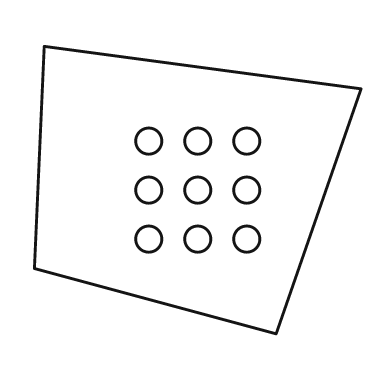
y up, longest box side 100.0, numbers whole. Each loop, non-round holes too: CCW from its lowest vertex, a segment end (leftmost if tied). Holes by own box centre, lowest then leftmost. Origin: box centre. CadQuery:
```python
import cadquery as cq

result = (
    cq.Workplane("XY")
    .moveTo(24.0, -44.0)
    .lineTo(50.0, 31.0)
    .lineTo(-47.0, 44.0)
    .lineTo(-50.0, -24.0)
    .close()
    .moveTo(-15.0, -15.0)
    .circle(4.0)
    .moveTo(0.0, -15.0)
    .circle(4.0)
    .moveTo(15.0, -15.0)
    .circle(4.0)
    .moveTo(-15.0, 0.0)
    .circle(4.0)
    .moveTo(0.0, 0.0)
    .circle(4.0)
    .moveTo(15.0, 0.0)
    .circle(4.0)
    .moveTo(-15.0, 15.0)
    .circle(4.0)
    .moveTo(0.0, 15.0)
    .circle(4.0)
    .moveTo(15.0, 15.0)
    .circle(4.0)
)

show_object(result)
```